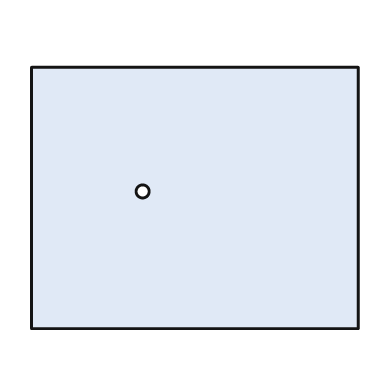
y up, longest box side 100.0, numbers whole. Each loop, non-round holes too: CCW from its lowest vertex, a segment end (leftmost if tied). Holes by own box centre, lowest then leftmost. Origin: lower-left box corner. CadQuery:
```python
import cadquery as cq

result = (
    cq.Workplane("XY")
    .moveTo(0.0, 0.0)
    .lineTo(100.0, 0.0)
    .lineTo(100.0, 80.0)
    .lineTo(0.0, 80.0)
    .close()
    .moveTo(34.0, 42.0)
    .circle(2.0)
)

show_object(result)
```